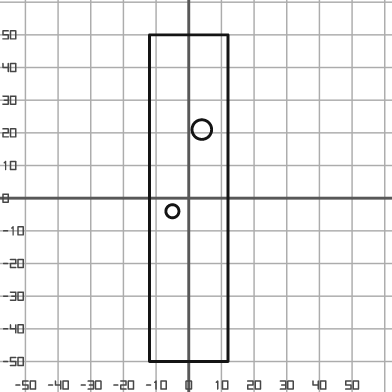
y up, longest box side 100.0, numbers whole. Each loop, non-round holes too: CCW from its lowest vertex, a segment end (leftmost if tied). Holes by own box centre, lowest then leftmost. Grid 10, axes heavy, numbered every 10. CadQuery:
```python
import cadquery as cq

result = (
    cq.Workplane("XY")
    .moveTo(-12.0, -50.0)
    .lineTo(12.0, -50.0)
    .lineTo(12.0, 50.0)
    .lineTo(-12.0, 50.0)
    .close()
    .moveTo(-5.0, -4.0)
    .circle(2.0)
    .moveTo(4.0, 21.0)
    .circle(3.0)
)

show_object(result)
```